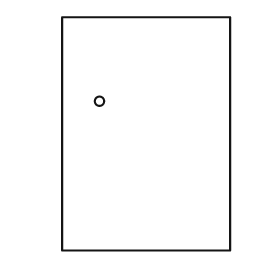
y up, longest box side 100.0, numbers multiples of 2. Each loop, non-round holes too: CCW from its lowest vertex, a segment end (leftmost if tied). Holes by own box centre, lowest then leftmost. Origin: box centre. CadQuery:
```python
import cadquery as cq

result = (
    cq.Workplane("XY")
    .moveTo(-36.0, -50.0)
    .lineTo(36.0, -50.0)
    .lineTo(36.0, 50.0)
    .lineTo(-36.0, 50.0)
    .close()
    .moveTo(-20.0, 14.0)
    .circle(2.0)
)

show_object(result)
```